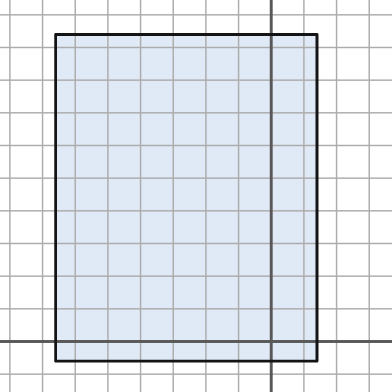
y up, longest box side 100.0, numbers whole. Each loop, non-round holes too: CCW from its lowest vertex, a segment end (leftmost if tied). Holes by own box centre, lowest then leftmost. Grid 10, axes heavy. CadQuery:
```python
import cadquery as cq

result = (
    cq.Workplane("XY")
    .moveTo(-66.0, -6.0)
    .lineTo(14.0, -6.0)
    .lineTo(14.0, 94.0)
    .lineTo(-66.0, 94.0)
    .close()
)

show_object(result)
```